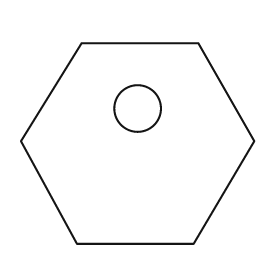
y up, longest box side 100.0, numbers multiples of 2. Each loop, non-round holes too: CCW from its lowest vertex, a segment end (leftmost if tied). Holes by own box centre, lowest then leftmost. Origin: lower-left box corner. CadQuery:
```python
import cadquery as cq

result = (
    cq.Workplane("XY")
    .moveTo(24.0, 0.0)
    .lineTo(74.0, 0.0)
    .lineTo(100.0, 44.0)
    .lineTo(76.0, 86.0)
    .lineTo(26.0, 86.0)
    .lineTo(0.0, 44.0)
    .close()
    .moveTo(50.0, 58.0)
    .circle(10.0)
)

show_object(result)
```